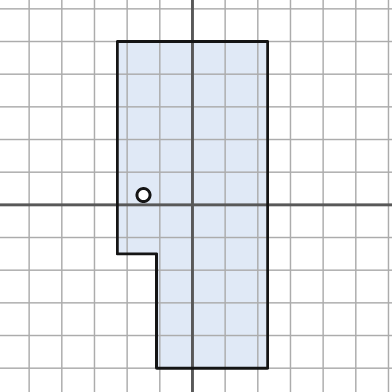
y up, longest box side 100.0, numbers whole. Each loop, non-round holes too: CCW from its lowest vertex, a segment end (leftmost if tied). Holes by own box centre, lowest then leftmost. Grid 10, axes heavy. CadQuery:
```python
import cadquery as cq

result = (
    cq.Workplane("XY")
    .moveTo(-11.0, -50.0)
    .lineTo(23.0, -50.0)
    .lineTo(23.0, 50.0)
    .lineTo(-23.0, 50.0)
    .lineTo(-23.0, -15.0)
    .lineTo(-11.0, -15.0)
    .close()
    .moveTo(-15.0, 3.0)
    .circle(2.0)
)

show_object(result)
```